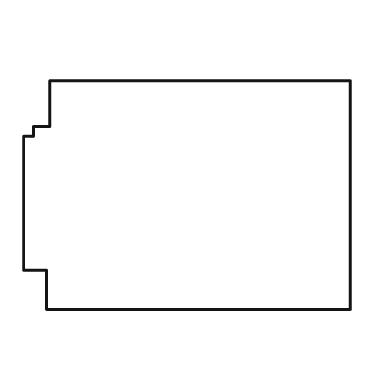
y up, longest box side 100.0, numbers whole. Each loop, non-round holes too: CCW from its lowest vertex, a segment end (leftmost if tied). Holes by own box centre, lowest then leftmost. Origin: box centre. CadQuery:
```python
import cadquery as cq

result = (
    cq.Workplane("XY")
    .moveTo(-43.0, -35.0)
    .lineTo(50.0, -35.0)
    .lineTo(50.0, 35.0)
    .lineTo(-42.0, 35.0)
    .lineTo(-42.0, 21.0)
    .lineTo(-47.0, 21.0)
    .lineTo(-47.0, 18.0)
    .lineTo(-50.0, 18.0)
    .lineTo(-50.0, -23.0)
    .lineTo(-43.0, -23.0)
    .close()
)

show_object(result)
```